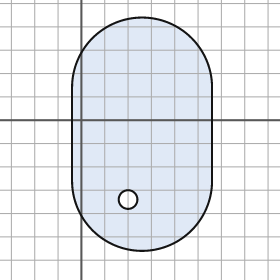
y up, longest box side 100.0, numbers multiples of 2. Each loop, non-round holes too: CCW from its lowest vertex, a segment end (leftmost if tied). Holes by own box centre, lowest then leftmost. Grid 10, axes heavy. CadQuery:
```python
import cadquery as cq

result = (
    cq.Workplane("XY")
    .moveTo(-4.0, -26.0)
    .threePointArc((26.0, -56.0), (56.0, -26.0))
    .lineTo(56.0, 14.0)
    .threePointArc((26.0, 44.0), (-4.0, 14.0))
    .close()
    .moveTo(20.0, -34.0)
    .circle(4.0)
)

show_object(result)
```